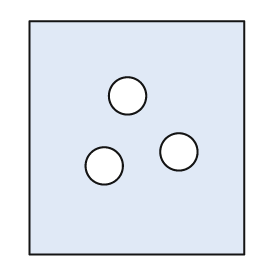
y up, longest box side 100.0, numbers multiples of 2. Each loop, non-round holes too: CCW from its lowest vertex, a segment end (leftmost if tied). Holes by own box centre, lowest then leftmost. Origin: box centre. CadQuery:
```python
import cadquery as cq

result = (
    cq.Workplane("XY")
    .moveTo(-46.0, -50.0)
    .lineTo(46.0, -50.0)
    .lineTo(46.0, 50.0)
    .lineTo(-46.0, 50.0)
    .close()
    .moveTo(-14.0, -12.0)
    .circle(8.0)
    .moveTo(18.0, -6.0)
    .circle(8.0)
    .moveTo(-4.0, 18.0)
    .circle(8.0)
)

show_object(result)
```